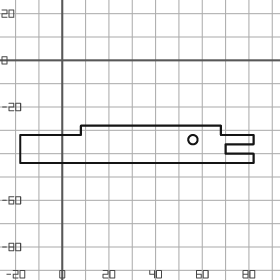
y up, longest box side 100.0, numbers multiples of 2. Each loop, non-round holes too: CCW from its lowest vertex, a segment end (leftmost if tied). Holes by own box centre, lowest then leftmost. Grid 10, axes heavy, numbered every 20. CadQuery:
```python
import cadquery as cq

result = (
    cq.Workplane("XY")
    .moveTo(-18.0, -44.0)
    .lineTo(82.0, -44.0)
    .lineTo(82.0, -40.0)
    .lineTo(70.0, -40.0)
    .lineTo(70.0, -36.0)
    .lineTo(82.0, -36.0)
    .lineTo(82.0, -32.0)
    .lineTo(68.0, -32.0)
    .lineTo(68.0, -28.0)
    .lineTo(8.0, -28.0)
    .lineTo(8.0, -32.0)
    .lineTo(-18.0, -32.0)
    .close()
    .moveTo(56.0, -34.0)
    .circle(2.0)
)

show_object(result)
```